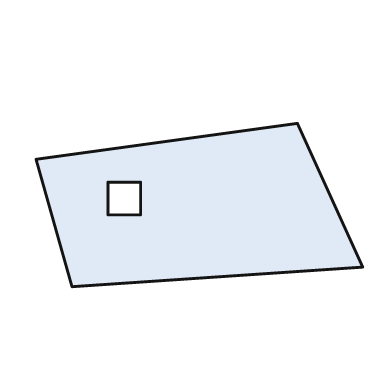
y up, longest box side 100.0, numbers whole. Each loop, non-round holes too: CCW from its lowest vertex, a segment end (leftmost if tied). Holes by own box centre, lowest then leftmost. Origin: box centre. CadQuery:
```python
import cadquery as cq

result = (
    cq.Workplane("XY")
    .moveTo(-39.0, -25.0)
    .lineTo(50.0, -19.0)
    .lineTo(30.0, 25.0)
    .lineTo(-50.0, 14.0)
    .close()
    .moveTo(-28.0, -3.0)
    .lineTo(-18.0, -3.0)
    .lineTo(-18.0, 7.0)
    .lineTo(-28.0, 7.0)
    .close()
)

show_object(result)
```